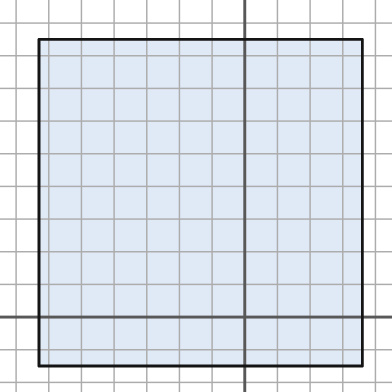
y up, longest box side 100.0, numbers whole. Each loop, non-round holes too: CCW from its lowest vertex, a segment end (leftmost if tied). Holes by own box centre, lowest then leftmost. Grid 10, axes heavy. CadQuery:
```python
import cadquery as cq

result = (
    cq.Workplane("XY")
    .moveTo(-63.0, -15.0)
    .lineTo(36.0, -15.0)
    .lineTo(36.0, 85.0)
    .lineTo(-63.0, 85.0)
    .close()
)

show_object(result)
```